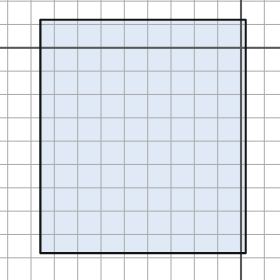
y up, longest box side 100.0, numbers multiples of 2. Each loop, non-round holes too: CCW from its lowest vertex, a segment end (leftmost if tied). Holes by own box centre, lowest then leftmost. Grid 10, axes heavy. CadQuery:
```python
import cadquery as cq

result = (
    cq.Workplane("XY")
    .moveTo(-86.0, -88.0)
    .lineTo(2.0, -88.0)
    .lineTo(2.0, 12.0)
    .lineTo(-86.0, 12.0)
    .close()
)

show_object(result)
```